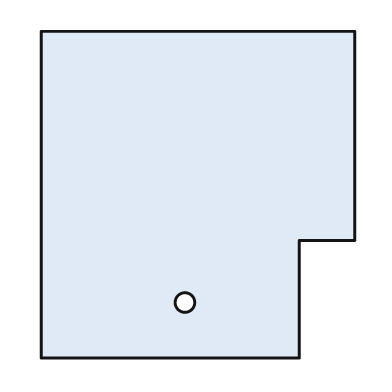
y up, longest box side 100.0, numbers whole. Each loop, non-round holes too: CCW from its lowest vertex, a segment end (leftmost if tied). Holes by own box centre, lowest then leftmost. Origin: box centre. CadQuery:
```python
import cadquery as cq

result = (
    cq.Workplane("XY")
    .moveTo(-48.0, -50.0)
    .lineTo(31.0, -50.0)
    .lineTo(31.0, -14.0)
    .lineTo(48.0, -14.0)
    .lineTo(48.0, 50.0)
    .lineTo(-48.0, 50.0)
    .close()
    .moveTo(-4.0, -33.0)
    .circle(3.0)
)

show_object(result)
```